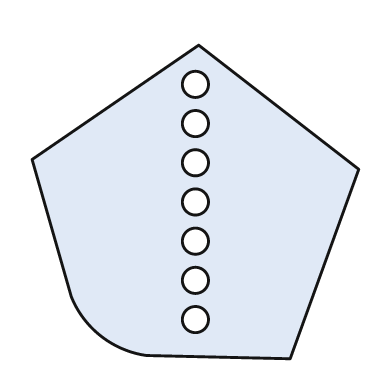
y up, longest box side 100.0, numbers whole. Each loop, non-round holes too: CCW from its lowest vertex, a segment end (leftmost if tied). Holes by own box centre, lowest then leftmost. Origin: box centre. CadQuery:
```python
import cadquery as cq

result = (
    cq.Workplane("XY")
    .moveTo(29.0, -48.0)
    .lineTo(50.0, 10.0)
    .lineTo(1.0, 48.0)
    .lineTo(-50.0, 13.0)
    .lineTo(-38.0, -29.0)
    .threePointArc((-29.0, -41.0), (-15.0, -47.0))
    .close()
    .moveTo(0.0, -36.0)
    .circle(4.0)
    .moveTo(0.0, -24.0)
    .circle(4.0)
    .moveTo(0.0, -12.0)
    .circle(4.0)
    .moveTo(0.0, 0.0)
    .circle(4.0)
    .moveTo(0.0, 12.0)
    .circle(4.0)
    .moveTo(0.0, 24.0)
    .circle(4.0)
    .moveTo(0.0, 36.0)
    .circle(4.0)
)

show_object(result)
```